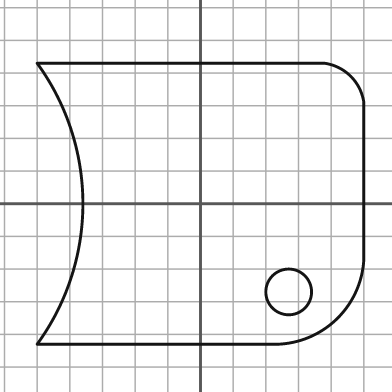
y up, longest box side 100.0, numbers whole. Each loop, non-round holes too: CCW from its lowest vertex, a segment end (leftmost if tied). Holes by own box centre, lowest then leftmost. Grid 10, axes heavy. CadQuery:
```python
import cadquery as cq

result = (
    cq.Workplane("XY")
    .moveTo(-50.0, -43.0)
    .lineTo(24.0, -43.0)
    .threePointArc((42.0, -35.0), (50.0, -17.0))
    .lineTo(50.0, 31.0)
    .threePointArc((46.0, 39.0), (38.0, 43.0))
    .lineTo(-50.0, 43.0)
    .threePointArc((-36.0, 0.0), (-50.0, -43.0))
    .close()
    .moveTo(27.0, -27.0)
    .circle(7.0)
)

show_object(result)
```